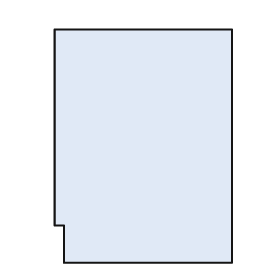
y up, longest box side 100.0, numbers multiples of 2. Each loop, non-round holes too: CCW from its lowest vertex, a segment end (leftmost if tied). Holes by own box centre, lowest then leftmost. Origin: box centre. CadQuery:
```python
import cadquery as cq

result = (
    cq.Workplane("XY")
    .moveTo(-34.0, -50.0)
    .lineTo(38.0, -50.0)
    .lineTo(38.0, 50.0)
    .lineTo(-38.0, 50.0)
    .lineTo(-38.0, -34.0)
    .lineTo(-34.0, -34.0)
    .close()
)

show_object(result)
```